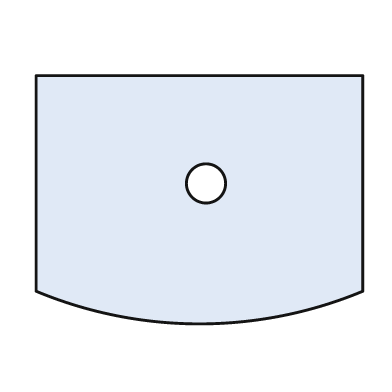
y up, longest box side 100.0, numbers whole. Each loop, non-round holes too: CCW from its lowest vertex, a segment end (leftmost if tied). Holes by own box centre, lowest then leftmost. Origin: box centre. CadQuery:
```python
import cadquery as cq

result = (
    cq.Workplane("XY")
    .moveTo(-50.0, -28.0)
    .threePointArc((0.0, -38.0), (50.0, -28.0))
    .lineTo(50.0, 38.0)
    .lineTo(-50.0, 38.0)
    .close()
    .moveTo(2.0, 5.0)
    .circle(6.0)
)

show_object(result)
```